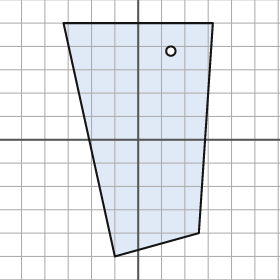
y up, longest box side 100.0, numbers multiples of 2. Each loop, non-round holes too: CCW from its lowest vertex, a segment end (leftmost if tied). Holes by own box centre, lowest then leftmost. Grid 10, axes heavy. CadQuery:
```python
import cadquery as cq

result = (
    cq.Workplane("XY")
    .moveTo(-10.0, -50.0)
    .lineTo(26.0, -40.0)
    .lineTo(32.0, 50.0)
    .lineTo(-32.0, 50.0)
    .close()
    .moveTo(14.0, 38.0)
    .circle(2.0)
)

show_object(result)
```